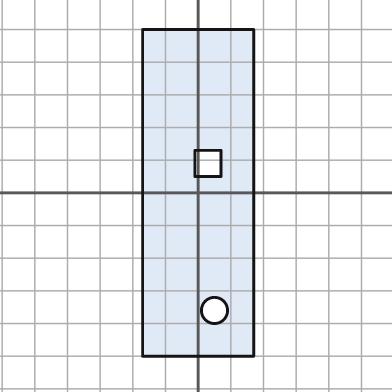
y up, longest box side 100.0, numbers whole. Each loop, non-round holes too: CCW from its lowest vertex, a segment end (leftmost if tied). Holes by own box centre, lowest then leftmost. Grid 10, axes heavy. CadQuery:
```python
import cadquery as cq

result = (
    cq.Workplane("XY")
    .moveTo(-17.0, -50.0)
    .lineTo(17.0, -50.0)
    .lineTo(17.0, 50.0)
    .lineTo(-17.0, 50.0)
    .close()
    .moveTo(5.0, -36.0)
    .circle(4.0)
    .moveTo(-1.0, 5.0)
    .lineTo(7.0, 5.0)
    .lineTo(7.0, 13.0)
    .lineTo(-1.0, 13.0)
    .close()
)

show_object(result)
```